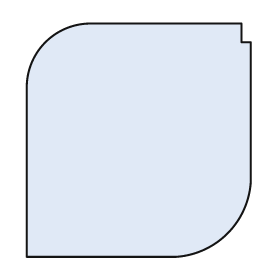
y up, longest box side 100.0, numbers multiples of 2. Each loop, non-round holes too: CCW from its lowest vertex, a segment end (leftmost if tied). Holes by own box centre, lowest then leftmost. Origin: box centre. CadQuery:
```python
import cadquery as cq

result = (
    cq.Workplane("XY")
    .moveTo(-48.0, -50.0)
    .lineTo(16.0, -50.0)
    .threePointArc((38.0, -40.0), (48.0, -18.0))
    .lineTo(48.0, 42.0)
    .lineTo(44.0, 42.0)
    .lineTo(44.0, 50.0)
    .lineTo(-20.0, 50.0)
    .threePointArc((-40.0, 42.0), (-48.0, 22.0))
    .close()
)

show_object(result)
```